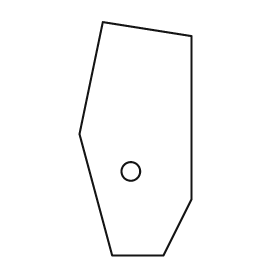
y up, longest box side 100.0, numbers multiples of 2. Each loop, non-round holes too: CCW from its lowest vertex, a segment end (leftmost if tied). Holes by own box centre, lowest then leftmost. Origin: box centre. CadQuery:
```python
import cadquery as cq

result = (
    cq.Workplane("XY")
    .moveTo(-10.0, -50.0)
    .lineTo(12.0, -50.0)
    .lineTo(24.0, -26.0)
    .lineTo(24.0, 44.0)
    .lineTo(-14.0, 50.0)
    .lineTo(-24.0, 2.0)
    .close()
    .moveTo(-2.0, -14.0)
    .circle(4.0)
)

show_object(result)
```